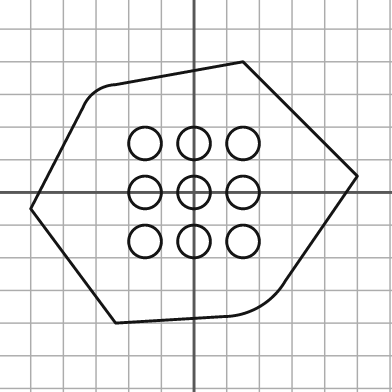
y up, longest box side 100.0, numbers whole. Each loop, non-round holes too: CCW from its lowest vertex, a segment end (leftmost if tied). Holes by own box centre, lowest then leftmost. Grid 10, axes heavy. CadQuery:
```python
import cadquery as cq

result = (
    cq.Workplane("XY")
    .moveTo(-24.0, -40.0)
    .lineTo(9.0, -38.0)
    .threePointArc((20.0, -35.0), (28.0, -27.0))
    .lineTo(50.0, 5.0)
    .lineTo(15.0, 40.0)
    .lineTo(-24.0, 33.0)
    .threePointArc((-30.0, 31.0), (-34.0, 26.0))
    .lineTo(-50.0, -5.0)
    .close()
    .moveTo(-15.0, -15.0)
    .circle(5.0)
    .moveTo(0.0, -15.0)
    .circle(5.0)
    .moveTo(15.0, -15.0)
    .circle(5.0)
    .moveTo(-15.0, 0.0)
    .circle(5.0)
    .moveTo(0.0, 0.0)
    .circle(5.0)
    .moveTo(15.0, 0.0)
    .circle(5.0)
    .moveTo(-15.0, 15.0)
    .circle(5.0)
    .moveTo(0.0, 15.0)
    .circle(5.0)
    .moveTo(15.0, 15.0)
    .circle(5.0)
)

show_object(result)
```